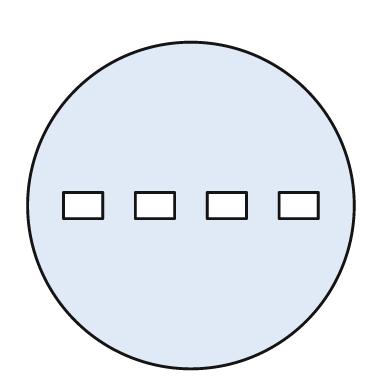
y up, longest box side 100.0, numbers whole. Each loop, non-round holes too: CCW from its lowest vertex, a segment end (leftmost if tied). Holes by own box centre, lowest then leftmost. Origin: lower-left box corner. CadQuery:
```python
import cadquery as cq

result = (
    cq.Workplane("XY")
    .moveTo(50.0, 50.0)
    .circle(50.0)
    .moveTo(11.0, 46.0)
    .lineTo(23.0, 46.0)
    .lineTo(23.0, 54.0)
    .lineTo(11.0, 54.0)
    .close()
    .moveTo(33.0, 46.0)
    .lineTo(45.0, 46.0)
    .lineTo(45.0, 54.0)
    .lineTo(33.0, 54.0)
    .close()
    .moveTo(55.0, 46.0)
    .lineTo(67.0, 46.0)
    .lineTo(67.0, 54.0)
    .lineTo(55.0, 54.0)
    .close()
    .moveTo(77.0, 46.0)
    .lineTo(89.0, 46.0)
    .lineTo(89.0, 54.0)
    .lineTo(77.0, 54.0)
    .close()
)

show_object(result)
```